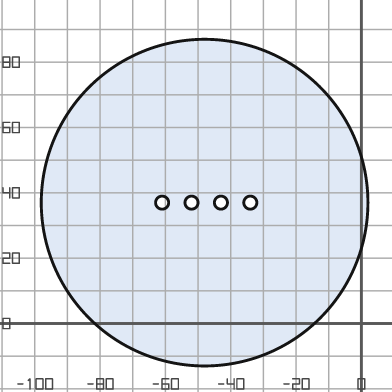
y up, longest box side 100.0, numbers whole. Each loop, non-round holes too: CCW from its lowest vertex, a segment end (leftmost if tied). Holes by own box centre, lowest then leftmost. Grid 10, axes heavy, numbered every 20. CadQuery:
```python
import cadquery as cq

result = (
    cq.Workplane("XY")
    .moveTo(-48.0, 37.0)
    .circle(50.0)
    .moveTo(-61.0, 37.0)
    .circle(2.0)
    .moveTo(-52.0, 37.0)
    .circle(2.0)
    .moveTo(-43.0, 37.0)
    .circle(2.0)
    .moveTo(-34.0, 37.0)
    .circle(2.0)
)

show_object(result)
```